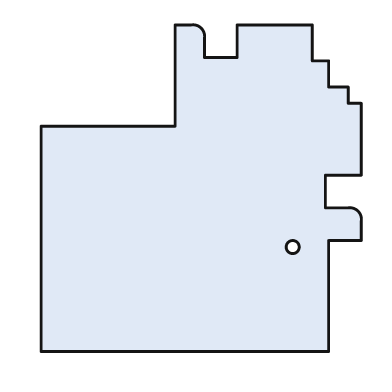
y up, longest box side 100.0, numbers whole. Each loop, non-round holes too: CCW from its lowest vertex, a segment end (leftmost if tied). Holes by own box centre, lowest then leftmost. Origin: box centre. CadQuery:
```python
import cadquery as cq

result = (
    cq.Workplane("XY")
    .moveTo(-49.0, -50.0)
    .lineTo(39.0, -50.0)
    .lineTo(39.0, -16.0)
    .lineTo(49.0, -16.0)
    .lineTo(49.0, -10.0)
    .threePointArc((48.0, -7.0), (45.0, -6.0))
    .lineTo(38.0, -6.0)
    .lineTo(38.0, 4.0)
    .lineTo(49.0, 4.0)
    .lineTo(49.0, 26.0)
    .lineTo(45.0, 26.0)
    .lineTo(45.0, 31.0)
    .lineTo(39.0, 31.0)
    .lineTo(39.0, 39.0)
    .lineTo(34.0, 39.0)
    .lineTo(34.0, 50.0)
    .lineTo(11.0, 50.0)
    .lineTo(11.0, 40.0)
    .lineTo(1.0, 40.0)
    .lineTo(1.0, 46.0)
    .threePointArc((0.0, 49.0), (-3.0, 50.0))
    .lineTo(-8.0, 50.0)
    .lineTo(-8.0, 19.0)
    .lineTo(-49.0, 19.0)
    .close()
    .moveTo(28.0, -18.0)
    .circle(2.0)
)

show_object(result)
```